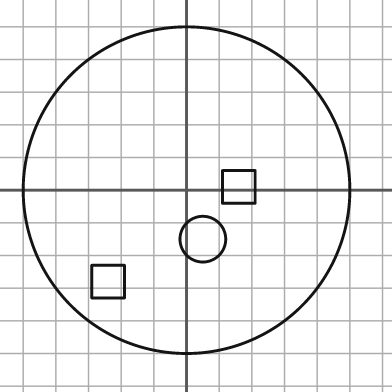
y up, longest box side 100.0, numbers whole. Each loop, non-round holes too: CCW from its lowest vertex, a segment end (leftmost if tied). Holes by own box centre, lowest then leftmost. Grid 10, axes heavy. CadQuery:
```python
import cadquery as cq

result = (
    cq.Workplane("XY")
    .moveTo(0.0, 0.0)
    .circle(50.0)
    .moveTo(-29.0, -33.0)
    .lineTo(-19.0, -33.0)
    .lineTo(-19.0, -23.0)
    .lineTo(-29.0, -23.0)
    .close()
    .moveTo(5.0, -15.0)
    .circle(7.0)
    .moveTo(11.0, -4.0)
    .lineTo(21.0, -4.0)
    .lineTo(21.0, 6.0)
    .lineTo(11.0, 6.0)
    .close()
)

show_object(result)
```